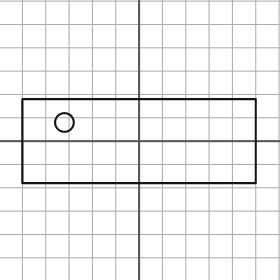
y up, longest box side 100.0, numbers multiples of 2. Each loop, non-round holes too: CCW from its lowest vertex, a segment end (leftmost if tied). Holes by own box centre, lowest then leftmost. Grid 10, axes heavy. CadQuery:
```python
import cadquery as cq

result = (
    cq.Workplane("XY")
    .moveTo(-50.0, -18.0)
    .lineTo(50.0, -18.0)
    .lineTo(50.0, 18.0)
    .lineTo(-50.0, 18.0)
    .close()
    .moveTo(-32.0, 8.0)
    .circle(4.0)
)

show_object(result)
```